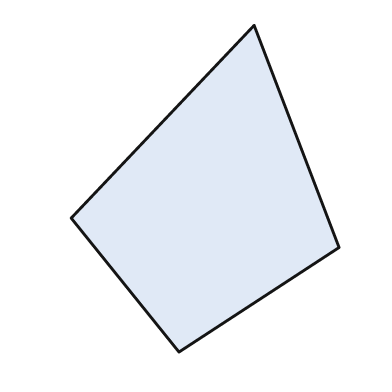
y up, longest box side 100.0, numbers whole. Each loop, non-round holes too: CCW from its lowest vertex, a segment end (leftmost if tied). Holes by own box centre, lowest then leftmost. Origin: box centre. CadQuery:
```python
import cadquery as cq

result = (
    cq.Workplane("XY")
    .moveTo(-8.0, -50.0)
    .lineTo(41.0, -18.0)
    .lineTo(15.0, 50.0)
    .lineTo(-41.0, -9.0)
    .close()
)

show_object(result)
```